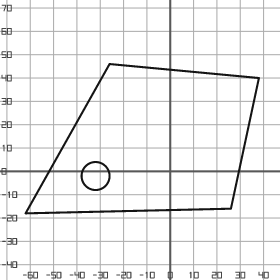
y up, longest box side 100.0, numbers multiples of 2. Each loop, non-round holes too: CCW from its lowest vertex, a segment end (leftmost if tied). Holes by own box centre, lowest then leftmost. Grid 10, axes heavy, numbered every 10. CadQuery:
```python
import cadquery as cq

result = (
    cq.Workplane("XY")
    .moveTo(-62.0, -18.0)
    .lineTo(26.0, -16.0)
    .lineTo(38.0, 40.0)
    .lineTo(-26.0, 46.0)
    .close()
    .moveTo(-32.0, -2.0)
    .circle(6.0)
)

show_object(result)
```